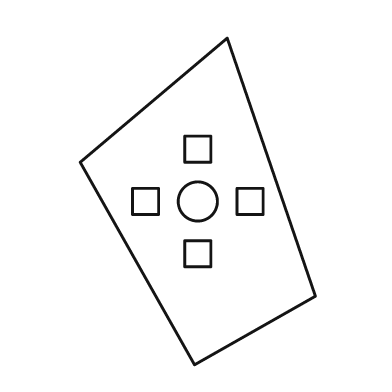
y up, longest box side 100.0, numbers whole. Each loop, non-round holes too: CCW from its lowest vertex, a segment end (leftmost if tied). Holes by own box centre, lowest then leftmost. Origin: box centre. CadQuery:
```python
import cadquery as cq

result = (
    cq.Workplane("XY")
    .moveTo(-1.0, -50.0)
    .lineTo(36.0, -29.0)
    .lineTo(9.0, 50.0)
    .lineTo(-36.0, 12.0)
    .close()
    .moveTo(-4.0, -20.0)
    .lineTo(4.0, -20.0)
    .lineTo(4.0, -12.0)
    .lineTo(-4.0, -12.0)
    .close()
    .moveTo(-20.0, -4.0)
    .lineTo(-12.0, -4.0)
    .lineTo(-12.0, 4.0)
    .lineTo(-20.0, 4.0)
    .close()
    .moveTo(0.0, 0.0)
    .circle(6.0)
    .moveTo(12.0, -4.0)
    .lineTo(20.0, -4.0)
    .lineTo(20.0, 4.0)
    .lineTo(12.0, 4.0)
    .close()
    .moveTo(-4.0, 12.0)
    .lineTo(4.0, 12.0)
    .lineTo(4.0, 20.0)
    .lineTo(-4.0, 20.0)
    .close()
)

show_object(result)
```